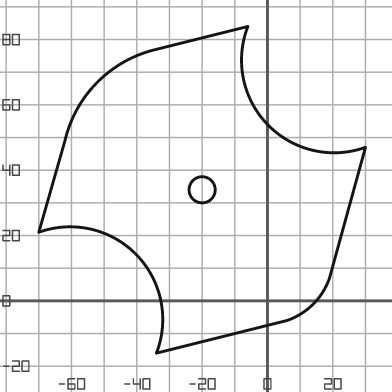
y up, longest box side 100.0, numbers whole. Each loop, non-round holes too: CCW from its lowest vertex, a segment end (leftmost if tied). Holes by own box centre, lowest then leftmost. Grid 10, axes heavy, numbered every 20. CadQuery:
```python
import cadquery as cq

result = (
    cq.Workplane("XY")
    .moveTo(-34.0, -16.0)
    .lineTo(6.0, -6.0)
    .threePointArc((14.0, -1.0), (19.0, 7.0))
    .lineTo(30.0, 47.0)
    .threePointArc((0.0, 54.0), (-6.0, 84.0))
    .lineTo(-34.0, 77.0)
    .threePointArc((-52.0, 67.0), (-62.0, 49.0))
    .lineTo(-70.0, 21.0)
    .threePointArc((-40.0, 14.0), (-34.0, -16.0))
    .close()
    .moveTo(-20.0, 34.0)
    .circle(4.0)
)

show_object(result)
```